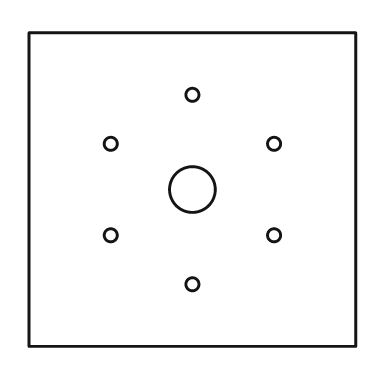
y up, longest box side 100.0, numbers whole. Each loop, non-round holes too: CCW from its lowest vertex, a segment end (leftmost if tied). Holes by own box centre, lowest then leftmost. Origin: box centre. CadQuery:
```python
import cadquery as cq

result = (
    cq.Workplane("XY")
    .moveTo(-50.0, -48.0)
    .lineTo(50.0, -48.0)
    .lineTo(50.0, 48.0)
    .lineTo(-50.0, 48.0)
    .close()
    .moveTo(0.0, -29.0)
    .circle(2.0)
    .moveTo(-25.0, -14.0)
    .circle(2.0)
    .moveTo(25.0, -14.0)
    .circle(2.0)
    .moveTo(0.0, 0.0)
    .circle(7.0)
    .moveTo(-25.0, 14.0)
    .circle(2.0)
    .moveTo(25.0, 14.0)
    .circle(2.0)
    .moveTo(0.0, 29.0)
    .circle(2.0)
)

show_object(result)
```